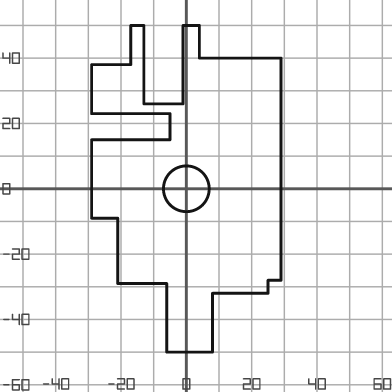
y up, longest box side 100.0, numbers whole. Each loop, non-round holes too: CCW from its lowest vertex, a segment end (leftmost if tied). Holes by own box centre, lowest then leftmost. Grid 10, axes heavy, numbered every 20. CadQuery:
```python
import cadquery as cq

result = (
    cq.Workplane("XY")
    .moveTo(-6.0, -50.0)
    .lineTo(8.0, -50.0)
    .lineTo(8.0, -32.0)
    .lineTo(25.0, -32.0)
    .lineTo(25.0, -28.0)
    .lineTo(29.0, -28.0)
    .lineTo(29.0, 40.0)
    .lineTo(4.0, 40.0)
    .lineTo(4.0, 50.0)
    .lineTo(-1.0, 50.0)
    .lineTo(-1.0, 26.0)
    .lineTo(-13.0, 26.0)
    .lineTo(-13.0, 50.0)
    .lineTo(-17.0, 50.0)
    .lineTo(-17.0, 38.0)
    .lineTo(-29.0, 38.0)
    .lineTo(-29.0, 23.0)
    .lineTo(-5.0, 23.0)
    .lineTo(-5.0, 15.0)
    .lineTo(-29.0, 15.0)
    .lineTo(-29.0, -9.0)
    .lineTo(-21.0, -9.0)
    .lineTo(-21.0, -29.0)
    .lineTo(-6.0, -29.0)
    .close()
    .moveTo(0.0, 0.0)
    .circle(7.0)
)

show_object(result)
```